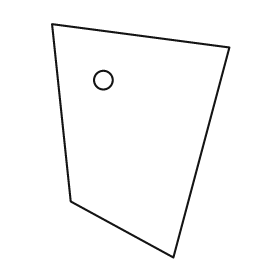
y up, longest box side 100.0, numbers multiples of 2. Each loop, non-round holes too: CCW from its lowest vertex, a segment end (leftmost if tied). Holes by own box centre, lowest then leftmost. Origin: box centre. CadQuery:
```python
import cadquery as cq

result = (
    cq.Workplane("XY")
    .moveTo(14.0, -50.0)
    .lineTo(38.0, 40.0)
    .lineTo(-38.0, 50.0)
    .lineTo(-30.0, -26.0)
    .close()
    .moveTo(-16.0, 26.0)
    .circle(4.0)
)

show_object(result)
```